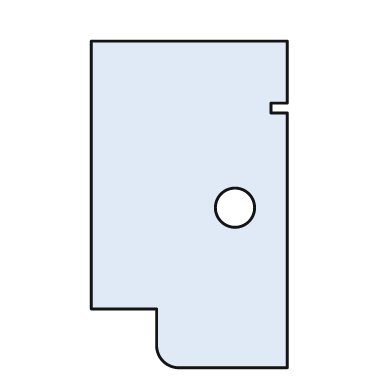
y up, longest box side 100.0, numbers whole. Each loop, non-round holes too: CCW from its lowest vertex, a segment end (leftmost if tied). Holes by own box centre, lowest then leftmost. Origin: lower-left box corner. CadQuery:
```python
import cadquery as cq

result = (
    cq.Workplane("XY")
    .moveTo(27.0, 0.0)
    .lineTo(60.0, 0.0)
    .lineTo(60.0, 78.0)
    .lineTo(55.0, 78.0)
    .lineTo(55.0, 81.0)
    .lineTo(60.0, 81.0)
    .lineTo(60.0, 100.0)
    .lineTo(0.0, 100.0)
    .lineTo(0.0, 18.0)
    .lineTo(20.0, 18.0)
    .lineTo(20.0, 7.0)
    .threePointArc((22.0, 2.0), (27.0, 0.0))
    .close()
    .moveTo(44.0, 49.0)
    .circle(6.0)
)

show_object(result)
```